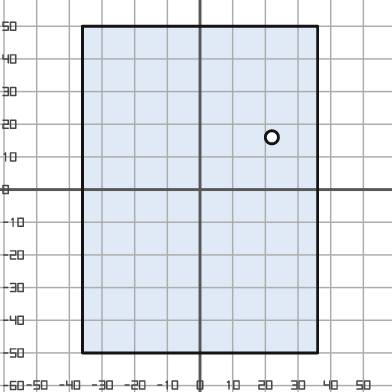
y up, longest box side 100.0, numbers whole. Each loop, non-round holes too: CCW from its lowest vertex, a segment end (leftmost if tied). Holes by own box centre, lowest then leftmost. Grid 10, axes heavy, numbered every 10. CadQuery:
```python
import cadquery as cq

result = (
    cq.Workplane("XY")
    .moveTo(-36.0, -50.0)
    .lineTo(36.0, -50.0)
    .lineTo(36.0, 50.0)
    .lineTo(-36.0, 50.0)
    .close()
    .moveTo(22.0, 16.0)
    .circle(2.0)
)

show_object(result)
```